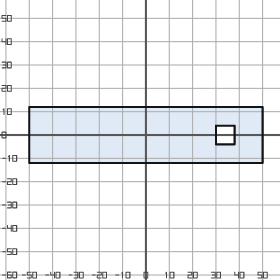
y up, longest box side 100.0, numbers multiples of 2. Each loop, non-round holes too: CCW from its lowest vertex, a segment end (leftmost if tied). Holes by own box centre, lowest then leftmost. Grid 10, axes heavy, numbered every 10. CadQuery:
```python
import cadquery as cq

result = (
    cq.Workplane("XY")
    .moveTo(-50.0, -12.0)
    .lineTo(50.0, -12.0)
    .lineTo(50.0, 12.0)
    .lineTo(-50.0, 12.0)
    .close()
    .moveTo(30.0, -4.0)
    .lineTo(38.0, -4.0)
    .lineTo(38.0, 4.0)
    .lineTo(30.0, 4.0)
    .close()
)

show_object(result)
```